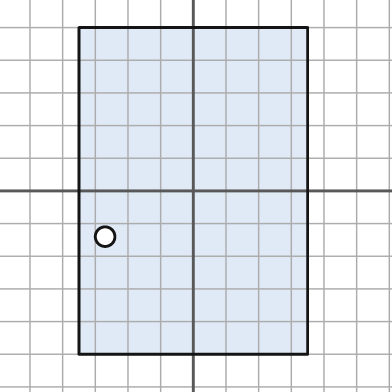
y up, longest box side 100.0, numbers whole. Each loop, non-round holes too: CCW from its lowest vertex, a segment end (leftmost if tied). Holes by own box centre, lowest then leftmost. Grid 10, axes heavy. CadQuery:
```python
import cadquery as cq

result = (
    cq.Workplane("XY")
    .moveTo(-35.0, -50.0)
    .lineTo(35.0, -50.0)
    .lineTo(35.0, 50.0)
    .lineTo(-35.0, 50.0)
    .close()
    .moveTo(-27.0, -14.0)
    .circle(3.0)
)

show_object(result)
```